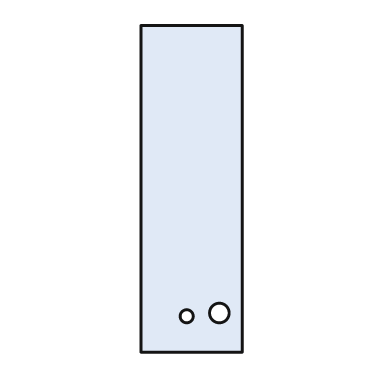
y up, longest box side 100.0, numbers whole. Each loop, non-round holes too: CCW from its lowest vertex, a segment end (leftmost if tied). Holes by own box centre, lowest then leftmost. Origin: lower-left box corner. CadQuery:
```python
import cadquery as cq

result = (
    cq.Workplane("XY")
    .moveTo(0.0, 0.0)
    .lineTo(31.0, 0.0)
    .lineTo(31.0, 100.0)
    .lineTo(0.0, 100.0)
    .close()
    .moveTo(14.0, 11.0)
    .circle(2.0)
    .moveTo(24.0, 12.0)
    .circle(3.0)
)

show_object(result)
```